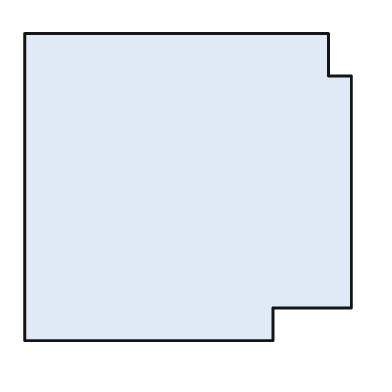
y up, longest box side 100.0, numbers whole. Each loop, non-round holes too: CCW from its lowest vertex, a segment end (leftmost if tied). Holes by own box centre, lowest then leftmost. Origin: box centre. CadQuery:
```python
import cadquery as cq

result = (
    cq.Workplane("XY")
    .moveTo(-50.0, -47.0)
    .lineTo(26.0, -47.0)
    .lineTo(26.0, -37.0)
    .lineTo(50.0, -37.0)
    .lineTo(50.0, 34.0)
    .lineTo(43.0, 34.0)
    .lineTo(43.0, 47.0)
    .lineTo(-50.0, 47.0)
    .close()
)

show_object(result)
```